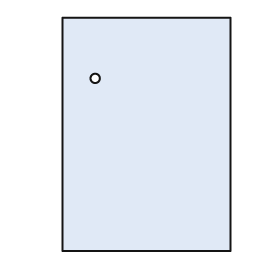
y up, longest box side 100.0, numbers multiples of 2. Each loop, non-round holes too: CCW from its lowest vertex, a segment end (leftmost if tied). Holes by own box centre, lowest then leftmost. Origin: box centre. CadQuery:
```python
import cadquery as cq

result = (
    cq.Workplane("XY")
    .moveTo(-36.0, -50.0)
    .lineTo(36.0, -50.0)
    .lineTo(36.0, 50.0)
    .lineTo(-36.0, 50.0)
    .close()
    .moveTo(-22.0, 24.0)
    .circle(2.0)
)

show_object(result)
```